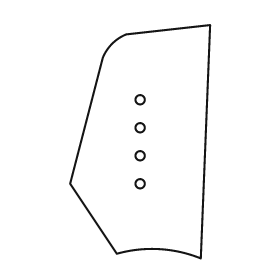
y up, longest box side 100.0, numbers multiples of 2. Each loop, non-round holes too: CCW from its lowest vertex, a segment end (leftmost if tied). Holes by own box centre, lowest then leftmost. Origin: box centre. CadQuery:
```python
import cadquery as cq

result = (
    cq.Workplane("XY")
    .moveTo(26.0, -50.0)
    .lineTo(30.0, 50.0)
    .lineTo(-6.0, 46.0)
    .threePointArc((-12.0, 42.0), (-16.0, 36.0))
    .lineTo(-30.0, -18.0)
    .lineTo(-10.0, -48.0)
    .threePointArc((8.0, -46.0), (26.0, -50.0))
    .close()
    .moveTo(0.0, -18.0)
    .circle(2.0)
    .moveTo(0.0, -6.0)
    .circle(2.0)
    .moveTo(0.0, 6.0)
    .circle(2.0)
    .moveTo(0.0, 18.0)
    .circle(2.0)
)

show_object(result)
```